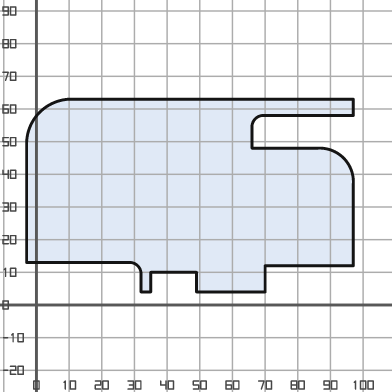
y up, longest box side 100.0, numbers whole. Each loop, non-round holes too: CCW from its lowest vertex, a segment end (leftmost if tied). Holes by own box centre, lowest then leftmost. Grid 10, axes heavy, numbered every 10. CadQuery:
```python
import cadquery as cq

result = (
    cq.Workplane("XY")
    .moveTo(32.0, 4.0)
    .lineTo(35.0, 4.0)
    .lineTo(35.0, 10.0)
    .lineTo(49.0, 10.0)
    .lineTo(49.0, 4.0)
    .lineTo(70.0, 4.0)
    .lineTo(70.0, 12.0)
    .lineTo(97.0, 12.0)
    .lineTo(97.0, 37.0)
    .threePointArc((94.0, 45.0), (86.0, 48.0))
    .lineTo(66.0, 48.0)
    .lineTo(66.0, 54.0)
    .threePointArc((67.0, 57.0), (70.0, 58.0))
    .lineTo(97.0, 58.0)
    .lineTo(97.0, 63.0)
    .lineTo(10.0, 63.0)
    .threePointArc((1.0, 59.0), (-3.0, 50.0))
    .lineTo(-3.0, 13.0)
    .lineTo(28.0, 13.0)
    .threePointArc((31.0, 12.0), (32.0, 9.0))
    .close()
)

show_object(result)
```